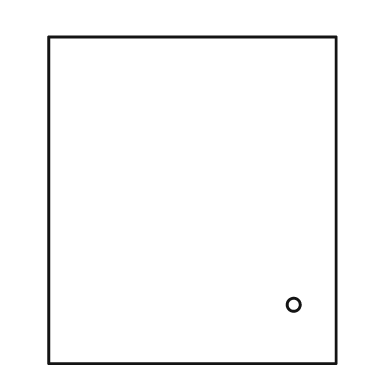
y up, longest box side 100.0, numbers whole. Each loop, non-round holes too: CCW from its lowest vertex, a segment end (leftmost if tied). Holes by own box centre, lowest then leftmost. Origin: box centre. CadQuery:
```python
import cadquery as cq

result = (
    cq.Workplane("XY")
    .moveTo(-44.0, -50.0)
    .lineTo(44.0, -50.0)
    .lineTo(44.0, 50.0)
    .lineTo(-44.0, 50.0)
    .close()
    .moveTo(31.0, -32.0)
    .circle(2.0)
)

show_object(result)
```